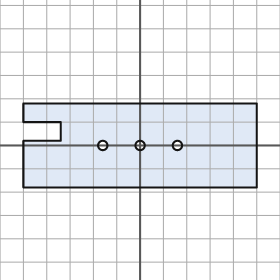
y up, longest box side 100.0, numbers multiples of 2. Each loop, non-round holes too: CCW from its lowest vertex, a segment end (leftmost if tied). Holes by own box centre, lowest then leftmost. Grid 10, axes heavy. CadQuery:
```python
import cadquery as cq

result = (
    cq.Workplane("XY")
    .moveTo(-50.0, -18.0)
    .lineTo(50.0, -18.0)
    .lineTo(50.0, 18.0)
    .lineTo(-50.0, 18.0)
    .lineTo(-50.0, 10.0)
    .lineTo(-34.0, 10.0)
    .lineTo(-34.0, 2.0)
    .lineTo(-50.0, 2.0)
    .close()
    .moveTo(-16.0, 0.0)
    .circle(2.0)
    .moveTo(0.0, 0.0)
    .circle(2.0)
    .moveTo(16.0, 0.0)
    .circle(2.0)
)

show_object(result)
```